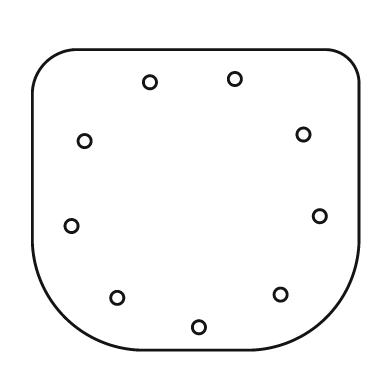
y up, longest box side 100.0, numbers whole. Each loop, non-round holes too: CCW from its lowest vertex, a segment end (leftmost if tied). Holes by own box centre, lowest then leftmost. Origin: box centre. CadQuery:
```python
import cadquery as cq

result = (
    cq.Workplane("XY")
    .moveTo(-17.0, -46.0)
    .lineTo(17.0, -46.0)
    .threePointArc((40.0, -36.0), (50.0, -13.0))
    .lineTo(50.0, 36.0)
    .threePointArc((47.0, 43.0), (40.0, 46.0))
    .lineTo(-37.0, 46.0)
    .threePointArc((-46.0, 42.0), (-50.0, 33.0))
    .lineTo(-50.0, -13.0)
    .threePointArc((-40.0, -36.0), (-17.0, -46.0))
    .close()
    .moveTo(1.0, -39.0)
    .circle(2.0)
    .moveTo(-24.0, -30.0)
    .circle(2.0)
    .moveTo(26.0, -29.0)
    .circle(2.0)
    .moveTo(-38.0, -8.0)
    .circle(2.0)
    .moveTo(38.0, -5.0)
    .circle(2.0)
    .moveTo(-34.0, 18.0)
    .circle(2.0)
    .moveTo(33.0, 20.0)
    .circle(2.0)
    .moveTo(-14.0, 36.0)
    .circle(2.0)
    .moveTo(12.0, 37.0)
    .circle(2.0)
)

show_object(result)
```